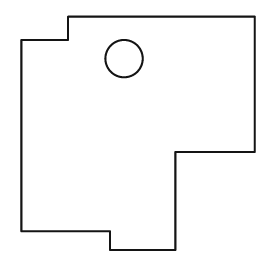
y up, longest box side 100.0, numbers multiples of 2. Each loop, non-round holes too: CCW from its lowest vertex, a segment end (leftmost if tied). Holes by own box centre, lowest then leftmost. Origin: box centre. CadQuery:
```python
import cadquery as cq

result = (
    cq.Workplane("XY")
    .moveTo(-12.0, -50.0)
    .lineTo(16.0, -50.0)
    .lineTo(16.0, -8.0)
    .lineTo(50.0, -8.0)
    .lineTo(50.0, 50.0)
    .lineTo(-30.0, 50.0)
    .lineTo(-30.0, 40.0)
    .lineTo(-50.0, 40.0)
    .lineTo(-50.0, -42.0)
    .lineTo(-12.0, -42.0)
    .close()
    .moveTo(-6.0, 32.0)
    .circle(8.0)
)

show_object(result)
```